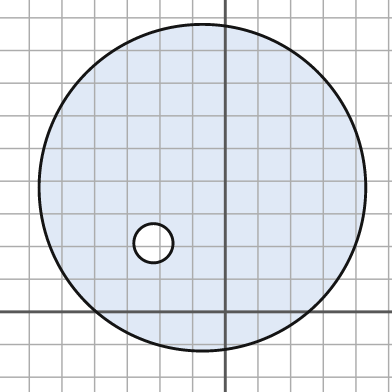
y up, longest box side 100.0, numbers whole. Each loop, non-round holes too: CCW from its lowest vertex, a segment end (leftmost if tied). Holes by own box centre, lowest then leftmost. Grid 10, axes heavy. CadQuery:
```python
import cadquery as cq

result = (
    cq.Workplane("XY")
    .moveTo(-7.0, 38.0)
    .circle(50.0)
    .moveTo(-22.0, 21.0)
    .circle(6.0)
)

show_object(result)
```